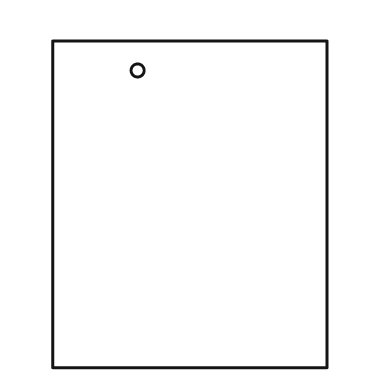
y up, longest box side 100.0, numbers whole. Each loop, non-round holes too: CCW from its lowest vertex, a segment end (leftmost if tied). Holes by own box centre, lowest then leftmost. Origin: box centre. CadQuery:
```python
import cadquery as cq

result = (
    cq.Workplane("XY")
    .moveTo(-42.0, -50.0)
    .lineTo(42.0, -50.0)
    .lineTo(42.0, 50.0)
    .lineTo(-42.0, 50.0)
    .close()
    .moveTo(-16.0, 41.0)
    .circle(2.0)
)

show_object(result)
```